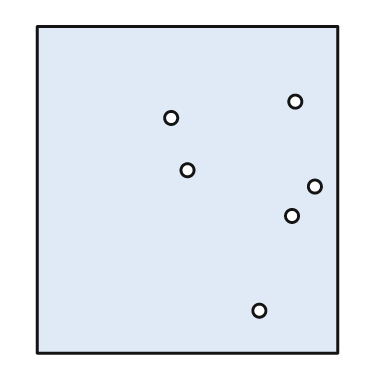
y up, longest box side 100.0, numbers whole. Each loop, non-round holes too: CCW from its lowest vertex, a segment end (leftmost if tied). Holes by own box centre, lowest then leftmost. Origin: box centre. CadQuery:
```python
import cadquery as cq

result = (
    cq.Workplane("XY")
    .moveTo(-46.0, -50.0)
    .lineTo(46.0, -50.0)
    .lineTo(46.0, 50.0)
    .lineTo(-46.0, 50.0)
    .close()
    .moveTo(22.0, -37.0)
    .circle(2.0)
    .moveTo(32.0, -8.0)
    .circle(2.0)
    .moveTo(39.0, 1.0)
    .circle(2.0)
    .moveTo(0.0, 6.0)
    .circle(2.0)
    .moveTo(-5.0, 22.0)
    .circle(2.0)
    .moveTo(33.0, 27.0)
    .circle(2.0)
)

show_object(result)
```